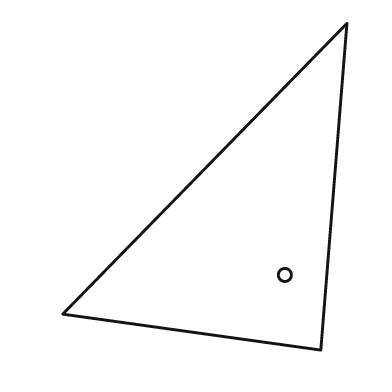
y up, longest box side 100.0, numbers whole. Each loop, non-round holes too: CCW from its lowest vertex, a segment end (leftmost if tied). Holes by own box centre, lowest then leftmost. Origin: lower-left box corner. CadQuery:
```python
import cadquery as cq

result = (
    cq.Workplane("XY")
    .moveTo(79.0, 0.0)
    .lineTo(87.0, 100.0)
    .lineTo(0.0, 11.0)
    .close()
    .moveTo(68.0, 23.0)
    .circle(2.0)
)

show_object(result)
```